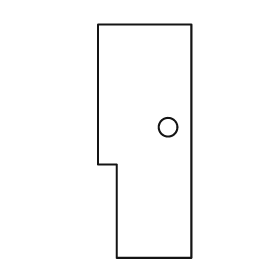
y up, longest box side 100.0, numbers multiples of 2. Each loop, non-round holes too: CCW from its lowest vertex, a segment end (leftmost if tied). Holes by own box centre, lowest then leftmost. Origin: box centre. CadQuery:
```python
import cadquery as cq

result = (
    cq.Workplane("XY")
    .moveTo(-12.0, -50.0)
    .lineTo(20.0, -50.0)
    .lineTo(20.0, 50.0)
    .lineTo(-20.0, 50.0)
    .lineTo(-20.0, -10.0)
    .lineTo(-12.0, -10.0)
    .close()
    .moveTo(10.0, 6.0)
    .circle(4.0)
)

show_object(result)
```